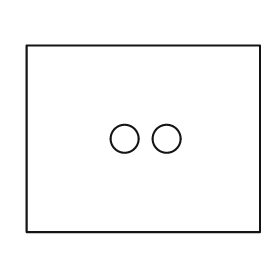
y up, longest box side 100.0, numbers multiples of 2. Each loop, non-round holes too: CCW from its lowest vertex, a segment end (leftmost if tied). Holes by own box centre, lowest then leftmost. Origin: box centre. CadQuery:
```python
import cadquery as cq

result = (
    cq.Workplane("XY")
    .moveTo(-50.0, -40.0)
    .lineTo(50.0, -40.0)
    .lineTo(50.0, 40.0)
    .lineTo(-50.0, 40.0)
    .close()
    .moveTo(-8.0, 0.0)
    .circle(6.0)
    .moveTo(10.0, 0.0)
    .circle(6.0)
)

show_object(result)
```